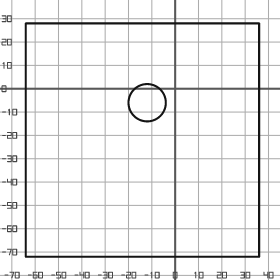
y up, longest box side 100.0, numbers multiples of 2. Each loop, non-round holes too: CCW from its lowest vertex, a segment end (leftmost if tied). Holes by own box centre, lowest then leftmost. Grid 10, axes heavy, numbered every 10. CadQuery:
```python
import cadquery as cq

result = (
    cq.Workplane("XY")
    .moveTo(-64.0, -72.0)
    .lineTo(36.0, -72.0)
    .lineTo(36.0, 28.0)
    .lineTo(-64.0, 28.0)
    .close()
    .moveTo(-12.0, -6.0)
    .circle(8.0)
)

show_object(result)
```